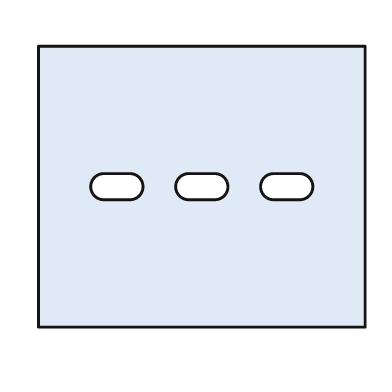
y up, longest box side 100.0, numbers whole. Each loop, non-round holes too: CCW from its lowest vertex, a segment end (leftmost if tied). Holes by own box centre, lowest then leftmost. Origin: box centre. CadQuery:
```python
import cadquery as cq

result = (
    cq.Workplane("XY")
    .moveTo(-50.0, -43.0)
    .lineTo(50.0, -43.0)
    .lineTo(50.0, 43.0)
    .lineTo(-50.0, 43.0)
    .close()
    .moveTo(-30.0, -4.0)
    .lineTo(-22.0, -4.0)
    .threePointArc((-18.0, 0.0), (-22.0, 4.0))
    .lineTo(-30.0, 4.0)
    .threePointArc((-34.0, 0.0), (-30.0, -4.0))
    .close()
    .moveTo(-4.0, -4.0)
    .lineTo(4.0, -4.0)
    .threePointArc((8.0, 0.0), (4.0, 4.0))
    .lineTo(-4.0, 4.0)
    .threePointArc((-8.0, 0.0), (-4.0, -4.0))
    .close()
    .moveTo(22.0, -4.0)
    .lineTo(30.0, -4.0)
    .threePointArc((34.0, 0.0), (30.0, 4.0))
    .lineTo(22.0, 4.0)
    .threePointArc((18.0, 0.0), (22.0, -4.0))
    .close()
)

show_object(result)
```